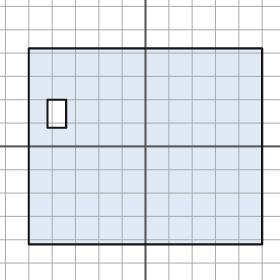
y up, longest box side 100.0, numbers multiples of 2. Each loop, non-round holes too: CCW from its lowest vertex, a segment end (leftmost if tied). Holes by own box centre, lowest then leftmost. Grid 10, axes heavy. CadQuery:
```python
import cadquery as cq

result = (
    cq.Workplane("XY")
    .moveTo(-50.0, -42.0)
    .lineTo(50.0, -42.0)
    .lineTo(50.0, 42.0)
    .lineTo(-50.0, 42.0)
    .close()
    .moveTo(-42.0, 8.0)
    .lineTo(-34.0, 8.0)
    .lineTo(-34.0, 20.0)
    .lineTo(-42.0, 20.0)
    .close()
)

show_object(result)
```